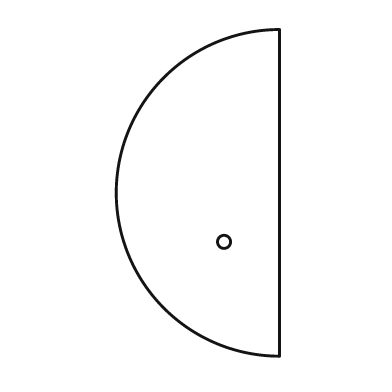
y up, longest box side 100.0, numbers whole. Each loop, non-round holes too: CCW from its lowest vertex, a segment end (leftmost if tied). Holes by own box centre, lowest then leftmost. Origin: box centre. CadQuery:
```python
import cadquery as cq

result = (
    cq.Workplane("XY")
    .moveTo(25.0, -50.0)
    .lineTo(25.0, 50.0)
    .threePointArc((-25.0, 0.0), (25.0, -50.0))
    .close()
    .moveTo(8.0, -15.0)
    .circle(2.0)
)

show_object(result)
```